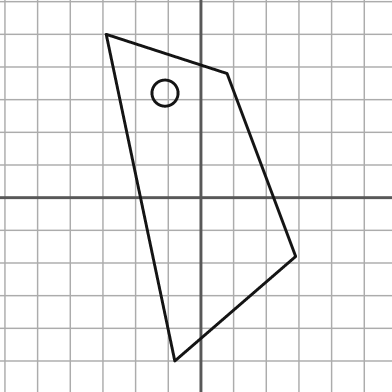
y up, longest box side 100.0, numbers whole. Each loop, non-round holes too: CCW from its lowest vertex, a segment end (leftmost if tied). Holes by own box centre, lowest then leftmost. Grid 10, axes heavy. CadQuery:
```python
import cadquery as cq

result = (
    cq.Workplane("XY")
    .moveTo(-8.0, -50.0)
    .lineTo(29.0, -18.0)
    .lineTo(8.0, 38.0)
    .lineTo(-29.0, 50.0)
    .close()
    .moveTo(-11.0, 32.0)
    .circle(4.0)
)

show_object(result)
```